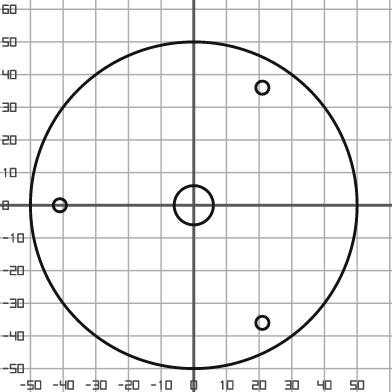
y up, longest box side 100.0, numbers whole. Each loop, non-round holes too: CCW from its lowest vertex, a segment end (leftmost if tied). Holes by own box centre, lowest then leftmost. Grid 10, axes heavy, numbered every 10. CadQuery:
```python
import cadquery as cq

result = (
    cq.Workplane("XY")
    .moveTo(0.0, 0.0)
    .circle(50.0)
    .moveTo(21.0, -36.0)
    .circle(2.0)
    .moveTo(-41.0, 0.0)
    .circle(2.0)
    .moveTo(0.0, 0.0)
    .circle(6.0)
    .moveTo(21.0, 36.0)
    .circle(2.0)
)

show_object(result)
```